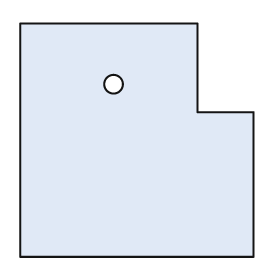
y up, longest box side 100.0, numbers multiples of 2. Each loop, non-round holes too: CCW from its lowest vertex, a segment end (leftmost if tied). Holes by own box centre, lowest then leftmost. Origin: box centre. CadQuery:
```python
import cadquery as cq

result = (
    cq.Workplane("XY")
    .moveTo(-50.0, -50.0)
    .lineTo(50.0, -50.0)
    .lineTo(50.0, 12.0)
    .lineTo(26.0, 12.0)
    .lineTo(26.0, 50.0)
    .lineTo(-50.0, 50.0)
    .close()
    .moveTo(-10.0, 24.0)
    .circle(4.0)
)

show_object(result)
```